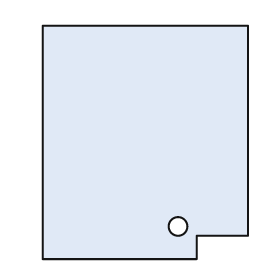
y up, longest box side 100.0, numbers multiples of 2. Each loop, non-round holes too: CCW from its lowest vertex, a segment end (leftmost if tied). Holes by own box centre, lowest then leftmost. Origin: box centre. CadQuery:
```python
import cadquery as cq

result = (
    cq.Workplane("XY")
    .moveTo(-44.0, -50.0)
    .lineTo(22.0, -50.0)
    .lineTo(22.0, -40.0)
    .lineTo(44.0, -40.0)
    .lineTo(44.0, 50.0)
    .lineTo(-44.0, 50.0)
    .close()
    .moveTo(14.0, -36.0)
    .circle(4.0)
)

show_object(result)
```